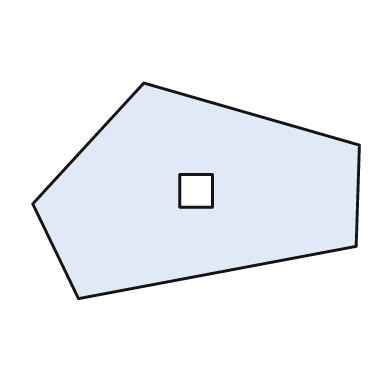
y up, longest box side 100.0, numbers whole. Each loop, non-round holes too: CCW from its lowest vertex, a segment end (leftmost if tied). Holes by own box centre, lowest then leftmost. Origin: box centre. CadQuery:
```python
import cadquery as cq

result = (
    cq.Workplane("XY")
    .moveTo(-36.0, -33.0)
    .lineTo(49.0, -17.0)
    .lineTo(50.0, 14.0)
    .lineTo(-16.0, 33.0)
    .lineTo(-50.0, -4.0)
    .close()
    .moveTo(-5.0, -5.0)
    .lineTo(5.0, -5.0)
    .lineTo(5.0, 5.0)
    .lineTo(-5.0, 5.0)
    .close()
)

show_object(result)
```